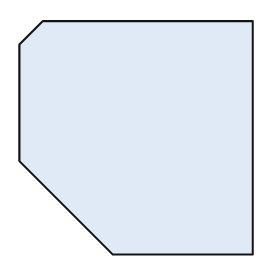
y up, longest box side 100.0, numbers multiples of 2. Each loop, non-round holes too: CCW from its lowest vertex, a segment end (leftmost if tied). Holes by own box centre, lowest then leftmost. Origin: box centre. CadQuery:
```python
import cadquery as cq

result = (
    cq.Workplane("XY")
    .moveTo(-10.0, -50.0)
    .lineTo(50.0, -50.0)
    .lineTo(50.0, 50.0)
    .lineTo(-40.0, 50.0)
    .lineTo(-50.0, 40.0)
    .lineTo(-50.0, -10.0)
    .close()
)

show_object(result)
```